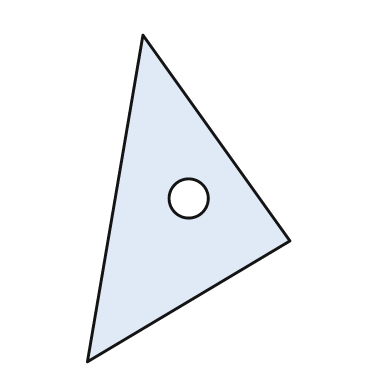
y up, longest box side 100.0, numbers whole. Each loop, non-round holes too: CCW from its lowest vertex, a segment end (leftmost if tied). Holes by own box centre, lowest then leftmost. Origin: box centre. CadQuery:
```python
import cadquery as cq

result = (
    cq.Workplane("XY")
    .moveTo(-31.0, -50.0)
    .lineTo(31.0, -13.0)
    .lineTo(-14.0, 50.0)
    .close()
    .moveTo(0.0, 0.0)
    .circle(6.0)
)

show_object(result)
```